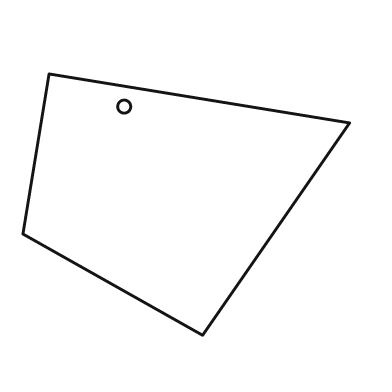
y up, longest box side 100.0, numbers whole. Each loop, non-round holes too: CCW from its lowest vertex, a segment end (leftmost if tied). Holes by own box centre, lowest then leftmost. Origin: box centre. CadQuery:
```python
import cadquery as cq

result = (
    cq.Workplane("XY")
    .moveTo(5.0, -40.0)
    .lineTo(50.0, 25.0)
    .lineTo(-42.0, 40.0)
    .lineTo(-50.0, -9.0)
    .close()
    .moveTo(-19.0, 30.0)
    .circle(2.0)
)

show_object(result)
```